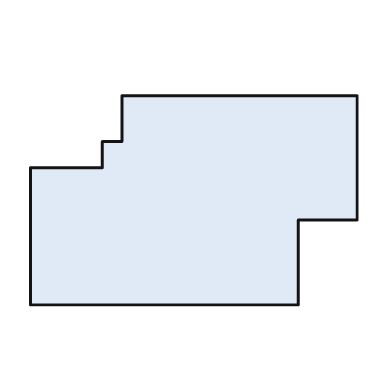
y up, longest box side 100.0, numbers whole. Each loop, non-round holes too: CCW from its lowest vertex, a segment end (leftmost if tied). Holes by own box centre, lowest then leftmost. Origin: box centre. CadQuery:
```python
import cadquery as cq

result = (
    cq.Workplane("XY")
    .moveTo(-50.0, -32.0)
    .lineTo(32.0, -32.0)
    .lineTo(32.0, -6.0)
    .lineTo(50.0, -6.0)
    .lineTo(50.0, 32.0)
    .lineTo(-22.0, 32.0)
    .lineTo(-22.0, 18.0)
    .lineTo(-28.0, 18.0)
    .lineTo(-28.0, 10.0)
    .lineTo(-50.0, 10.0)
    .close()
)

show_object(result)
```